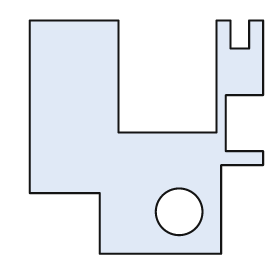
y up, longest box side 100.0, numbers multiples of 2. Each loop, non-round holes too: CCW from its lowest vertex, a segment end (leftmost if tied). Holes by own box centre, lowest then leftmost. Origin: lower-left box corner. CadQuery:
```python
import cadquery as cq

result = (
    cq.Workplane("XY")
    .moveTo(30.0, 0.0)
    .lineTo(82.0, 0.0)
    .lineTo(82.0, 38.0)
    .lineTo(100.0, 38.0)
    .lineTo(100.0, 44.0)
    .lineTo(84.0, 44.0)
    .lineTo(84.0, 68.0)
    .lineTo(100.0, 68.0)
    .lineTo(100.0, 100.0)
    .lineTo(94.0, 100.0)
    .lineTo(94.0, 88.0)
    .lineTo(86.0, 88.0)
    .lineTo(86.0, 100.0)
    .lineTo(80.0, 100.0)
    .lineTo(80.0, 52.0)
    .lineTo(38.0, 52.0)
    .lineTo(38.0, 100.0)
    .lineTo(0.0, 100.0)
    .lineTo(0.0, 26.0)
    .lineTo(30.0, 26.0)
    .close()
    .moveTo(64.0, 18.0)
    .circle(10.0)
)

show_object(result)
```